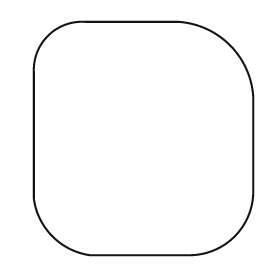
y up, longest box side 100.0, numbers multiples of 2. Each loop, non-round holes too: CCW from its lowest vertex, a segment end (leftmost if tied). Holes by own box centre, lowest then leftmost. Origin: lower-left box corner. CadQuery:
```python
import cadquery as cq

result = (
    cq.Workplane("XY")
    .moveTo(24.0, 0.0)
    .lineTo(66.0, 0.0)
    .threePointArc((86.0, 8.0), (94.0, 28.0))
    .lineTo(94.0, 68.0)
    .threePointArc((84.0, 90.0), (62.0, 100.0))
    .lineTo(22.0, 100.0)
    .threePointArc((6.0, 94.0), (0.0, 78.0))
    .lineTo(0.0, 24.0)
    .threePointArc((8.0, 8.0), (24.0, 0.0))
    .close()
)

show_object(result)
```